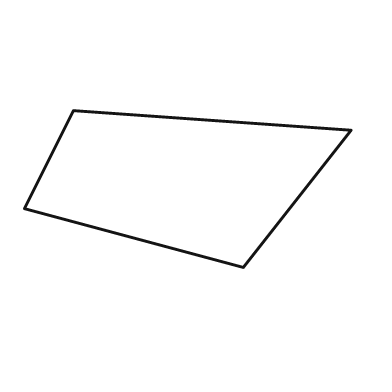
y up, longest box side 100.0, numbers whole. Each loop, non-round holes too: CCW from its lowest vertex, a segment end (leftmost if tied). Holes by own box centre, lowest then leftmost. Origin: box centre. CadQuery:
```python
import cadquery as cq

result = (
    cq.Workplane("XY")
    .moveTo(17.0, -24.0)
    .lineTo(50.0, 18.0)
    .lineTo(-35.0, 24.0)
    .lineTo(-50.0, -6.0)
    .close()
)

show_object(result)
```